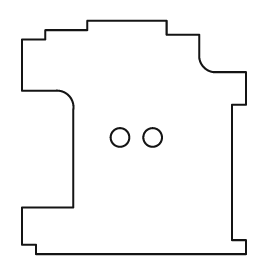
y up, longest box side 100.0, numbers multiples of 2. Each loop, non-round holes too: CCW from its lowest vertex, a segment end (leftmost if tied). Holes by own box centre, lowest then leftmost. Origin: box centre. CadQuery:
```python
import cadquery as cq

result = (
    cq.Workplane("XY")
    .moveTo(-42.0, -50.0)
    .lineTo(48.0, -50.0)
    .lineTo(48.0, -44.0)
    .lineTo(42.0, -44.0)
    .lineTo(42.0, 14.0)
    .lineTo(48.0, 14.0)
    .lineTo(48.0, 28.0)
    .lineTo(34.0, 28.0)
    .threePointArc((30.0, 30.0), (28.0, 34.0))
    .lineTo(28.0, 44.0)
    .lineTo(14.0, 44.0)
    .lineTo(14.0, 50.0)
    .lineTo(-20.0, 50.0)
    .lineTo(-20.0, 46.0)
    .lineTo(-38.0, 46.0)
    .lineTo(-38.0, 42.0)
    .lineTo(-48.0, 42.0)
    .lineTo(-48.0, 20.0)
    .lineTo(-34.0, 20.0)
    .threePointArc((-28.0, 18.0), (-26.0, 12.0))
    .lineTo(-26.0, -30.0)
    .lineTo(-48.0, -30.0)
    .lineTo(-48.0, -46.0)
    .lineTo(-42.0, -46.0)
    .close()
    .moveTo(-6.0, 0.0)
    .circle(4.0)
    .moveTo(8.0, 0.0)
    .circle(4.0)
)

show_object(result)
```